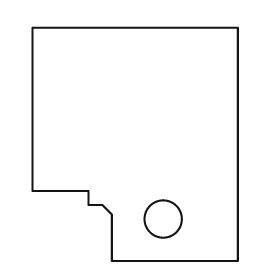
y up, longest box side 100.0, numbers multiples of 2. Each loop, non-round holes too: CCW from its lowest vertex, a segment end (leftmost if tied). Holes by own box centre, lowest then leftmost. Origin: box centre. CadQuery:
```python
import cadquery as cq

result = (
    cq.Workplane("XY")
    .moveTo(-10.0, -50.0)
    .lineTo(44.0, -50.0)
    .lineTo(44.0, 50.0)
    .lineTo(-44.0, 50.0)
    .lineTo(-44.0, -20.0)
    .lineTo(-20.0, -20.0)
    .lineTo(-20.0, -26.0)
    .lineTo(-14.0, -26.0)
    .lineTo(-10.0, -30.0)
    .close()
    .moveTo(12.0, -32.0)
    .circle(8.0)
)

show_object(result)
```